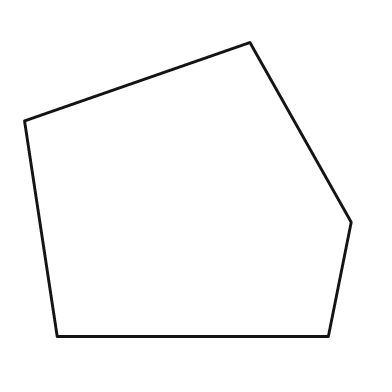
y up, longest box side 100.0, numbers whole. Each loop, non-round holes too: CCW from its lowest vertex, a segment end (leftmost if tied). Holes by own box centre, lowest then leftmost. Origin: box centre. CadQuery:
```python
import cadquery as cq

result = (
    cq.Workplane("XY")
    .moveTo(-40.0, -45.0)
    .lineTo(43.0, -45.0)
    .lineTo(50.0, -10.0)
    .lineTo(19.0, 45.0)
    .lineTo(-50.0, 21.0)
    .close()
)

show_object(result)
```